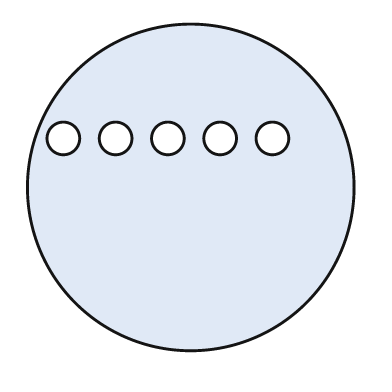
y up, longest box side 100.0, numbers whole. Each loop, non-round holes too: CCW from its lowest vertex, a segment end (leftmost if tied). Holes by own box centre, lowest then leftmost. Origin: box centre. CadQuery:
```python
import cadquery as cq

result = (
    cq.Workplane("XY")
    .moveTo(0.0, 0.0)
    .circle(50.0)
    .moveTo(-39.0, 15.0)
    .circle(5.0)
    .moveTo(-23.0, 15.0)
    .circle(5.0)
    .moveTo(-7.0, 15.0)
    .circle(5.0)
    .moveTo(9.0, 15.0)
    .circle(5.0)
    .moveTo(25.0, 15.0)
    .circle(5.0)
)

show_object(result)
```